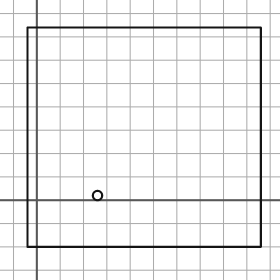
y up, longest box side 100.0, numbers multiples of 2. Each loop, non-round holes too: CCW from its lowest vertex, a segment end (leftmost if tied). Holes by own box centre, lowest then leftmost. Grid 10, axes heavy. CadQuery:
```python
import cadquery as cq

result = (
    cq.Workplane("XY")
    .moveTo(-4.0, -20.0)
    .lineTo(96.0, -20.0)
    .lineTo(96.0, 74.0)
    .lineTo(-4.0, 74.0)
    .close()
    .moveTo(26.0, 2.0)
    .circle(2.0)
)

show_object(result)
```